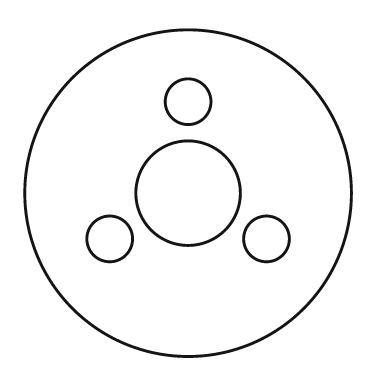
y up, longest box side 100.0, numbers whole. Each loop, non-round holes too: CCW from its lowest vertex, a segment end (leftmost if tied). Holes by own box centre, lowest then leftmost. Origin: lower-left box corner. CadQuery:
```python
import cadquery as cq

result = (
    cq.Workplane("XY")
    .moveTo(50.0, 50.0)
    .circle(50.0)
    .moveTo(26.0, 36.0)
    .circle(7.0)
    .moveTo(74.0, 36.0)
    .circle(7.0)
    .moveTo(50.0, 50.0)
    .circle(16.0)
    .moveTo(50.0, 78.0)
    .circle(7.0)
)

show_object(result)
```